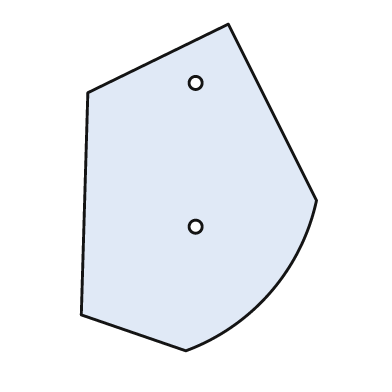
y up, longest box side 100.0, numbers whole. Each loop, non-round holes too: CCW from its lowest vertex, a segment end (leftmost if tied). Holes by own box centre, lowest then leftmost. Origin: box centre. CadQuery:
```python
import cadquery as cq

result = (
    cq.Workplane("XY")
    .moveTo(-4.0, -50.0)
    .threePointArc((22.0, -32.0), (36.0, -4.0))
    .lineTo(9.0, 50.0)
    .lineTo(-34.0, 29.0)
    .lineTo(-36.0, -39.0)
    .close()
    .moveTo(-1.0, -12.0)
    .circle(2.0)
    .moveTo(-1.0, 32.0)
    .circle(2.0)
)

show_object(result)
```